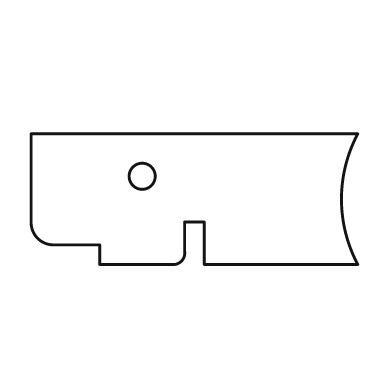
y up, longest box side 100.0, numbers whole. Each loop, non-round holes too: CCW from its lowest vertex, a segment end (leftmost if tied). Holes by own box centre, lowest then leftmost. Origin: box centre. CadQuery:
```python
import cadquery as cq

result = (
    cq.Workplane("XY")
    .moveTo(-29.0, -20.0)
    .lineTo(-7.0, -20.0)
    .threePointArc((-4.0, -19.0), (-3.0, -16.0))
    .lineTo(-3.0, -7.0)
    .lineTo(3.0, -7.0)
    .lineTo(3.0, -20.0)
    .lineTo(50.0, -20.0)
    .threePointArc((45.0, 0.0), (50.0, 20.0))
    .lineTo(-50.0, 20.0)
    .lineTo(-50.0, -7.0)
    .threePointArc((-48.0, -12.0), (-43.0, -14.0))
    .lineTo(-29.0, -14.0)
    .close()
    .moveTo(-16.0, 7.0)
    .circle(4.0)
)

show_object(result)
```